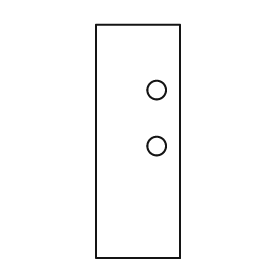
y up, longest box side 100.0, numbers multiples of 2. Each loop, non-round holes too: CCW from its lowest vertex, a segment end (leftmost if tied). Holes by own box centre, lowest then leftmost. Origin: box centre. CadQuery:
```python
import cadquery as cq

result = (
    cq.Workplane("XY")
    .moveTo(-18.0, -50.0)
    .lineTo(18.0, -50.0)
    .lineTo(18.0, 50.0)
    .lineTo(-18.0, 50.0)
    .close()
    .moveTo(8.0, -2.0)
    .circle(4.0)
    .moveTo(8.0, 22.0)
    .circle(4.0)
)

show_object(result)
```